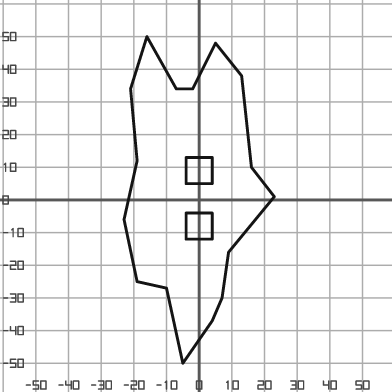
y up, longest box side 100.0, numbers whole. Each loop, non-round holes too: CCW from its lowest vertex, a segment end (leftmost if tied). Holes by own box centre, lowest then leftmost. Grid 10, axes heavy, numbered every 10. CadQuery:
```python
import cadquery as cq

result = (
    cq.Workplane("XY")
    .moveTo(-5.0, -50.0)
    .lineTo(4.0, -37.0)
    .lineTo(7.0, -30.0)
    .lineTo(9.0, -16.0)
    .lineTo(23.0, 1.0)
    .lineTo(16.0, 10.0)
    .lineTo(13.0, 38.0)
    .lineTo(5.0, 48.0)
    .lineTo(-2.0, 34.0)
    .lineTo(-7.0, 34.0)
    .lineTo(-16.0, 50.0)
    .lineTo(-21.0, 34.0)
    .lineTo(-19.0, 12.0)
    .lineTo(-23.0, -6.0)
    .lineTo(-19.0, -25.0)
    .lineTo(-10.0, -27.0)
    .close()
    .moveTo(-4.0, -12.0)
    .lineTo(4.0, -12.0)
    .lineTo(4.0, -4.0)
    .lineTo(-4.0, -4.0)
    .close()
    .moveTo(-4.0, 5.0)
    .lineTo(4.0, 5.0)
    .lineTo(4.0, 13.0)
    .lineTo(-4.0, 13.0)
    .close()
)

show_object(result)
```